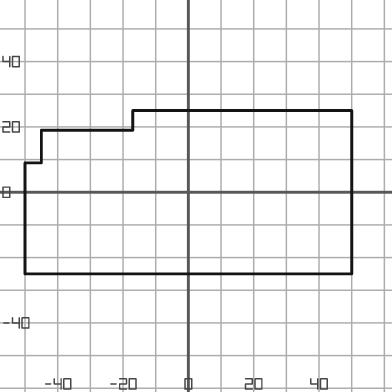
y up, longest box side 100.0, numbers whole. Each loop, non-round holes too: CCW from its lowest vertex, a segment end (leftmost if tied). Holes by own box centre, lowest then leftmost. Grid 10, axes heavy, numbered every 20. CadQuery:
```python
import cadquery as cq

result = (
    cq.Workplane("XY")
    .moveTo(-50.0, -25.0)
    .lineTo(50.0, -25.0)
    .lineTo(50.0, 25.0)
    .lineTo(-17.0, 25.0)
    .lineTo(-17.0, 19.0)
    .lineTo(-45.0, 19.0)
    .lineTo(-45.0, 9.0)
    .lineTo(-50.0, 9.0)
    .close()
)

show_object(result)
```